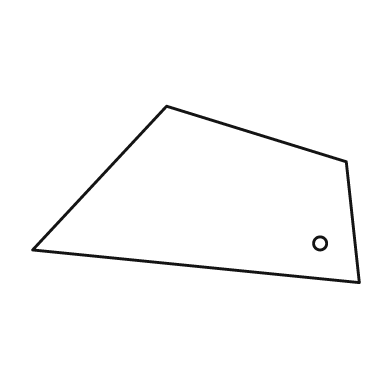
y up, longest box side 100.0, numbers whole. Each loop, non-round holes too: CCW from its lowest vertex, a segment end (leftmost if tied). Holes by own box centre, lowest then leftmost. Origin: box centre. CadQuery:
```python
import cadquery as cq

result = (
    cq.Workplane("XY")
    .moveTo(50.0, -27.0)
    .lineTo(46.0, 10.0)
    .lineTo(-9.0, 27.0)
    .lineTo(-50.0, -17.0)
    .close()
    .moveTo(38.0, -15.0)
    .circle(2.0)
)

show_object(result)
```